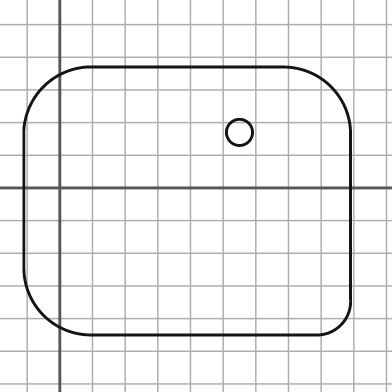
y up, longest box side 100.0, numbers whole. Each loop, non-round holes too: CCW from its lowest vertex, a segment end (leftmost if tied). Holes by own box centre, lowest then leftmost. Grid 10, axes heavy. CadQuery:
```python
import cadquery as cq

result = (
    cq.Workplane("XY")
    .moveTo(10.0, -45.0)
    .lineTo(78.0, -45.0)
    .threePointArc((86.0, -42.0), (89.0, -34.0))
    .lineTo(89.0, 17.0)
    .threePointArc((83.0, 31.0), (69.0, 37.0))
    .lineTo(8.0, 37.0)
    .threePointArc((-5.0, 31.0), (-11.0, 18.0))
    .lineTo(-11.0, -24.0)
    .threePointArc((-5.0, -39.0), (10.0, -45.0))
    .close()
    .moveTo(55.0, 17.0)
    .circle(4.0)
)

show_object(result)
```